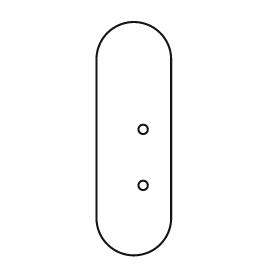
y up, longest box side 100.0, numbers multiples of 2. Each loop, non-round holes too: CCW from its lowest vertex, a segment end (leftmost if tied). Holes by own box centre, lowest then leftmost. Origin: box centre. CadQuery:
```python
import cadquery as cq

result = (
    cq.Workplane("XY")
    .moveTo(-16.0, -34.0)
    .threePointArc((0.0, -50.0), (16.0, -34.0))
    .lineTo(16.0, 34.0)
    .threePointArc((0.0, 50.0), (-16.0, 34.0))
    .close()
    .moveTo(4.0, -20.0)
    .circle(2.0)
    .moveTo(4.0, 4.0)
    .circle(2.0)
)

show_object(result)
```